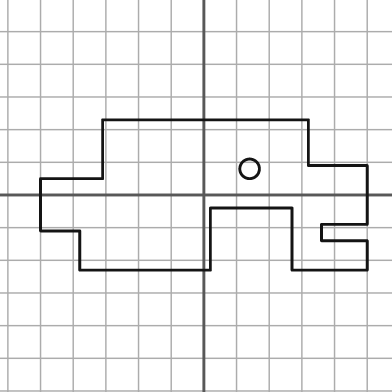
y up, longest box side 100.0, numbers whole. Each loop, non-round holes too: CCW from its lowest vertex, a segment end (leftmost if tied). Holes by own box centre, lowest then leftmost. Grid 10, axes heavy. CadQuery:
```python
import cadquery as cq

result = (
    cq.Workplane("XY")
    .moveTo(-38.0, -23.0)
    .lineTo(2.0, -23.0)
    .lineTo(2.0, -4.0)
    .lineTo(27.0, -4.0)
    .lineTo(27.0, -23.0)
    .lineTo(50.0, -23.0)
    .lineTo(50.0, -14.0)
    .lineTo(36.0, -14.0)
    .lineTo(36.0, -9.0)
    .lineTo(50.0, -9.0)
    .lineTo(50.0, 9.0)
    .lineTo(32.0, 9.0)
    .lineTo(32.0, 23.0)
    .lineTo(-31.0, 23.0)
    .lineTo(-31.0, 5.0)
    .lineTo(-50.0, 5.0)
    .lineTo(-50.0, -11.0)
    .lineTo(-38.0, -11.0)
    .close()
    .moveTo(14.0, 8.0)
    .circle(3.0)
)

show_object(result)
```